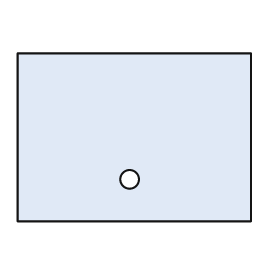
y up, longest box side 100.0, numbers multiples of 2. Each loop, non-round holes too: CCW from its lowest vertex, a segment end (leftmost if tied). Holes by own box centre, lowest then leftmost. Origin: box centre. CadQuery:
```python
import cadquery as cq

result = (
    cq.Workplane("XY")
    .moveTo(-50.0, -36.0)
    .lineTo(50.0, -36.0)
    .lineTo(50.0, 36.0)
    .lineTo(-50.0, 36.0)
    .close()
    .moveTo(-2.0, -18.0)
    .circle(4.0)
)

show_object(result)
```